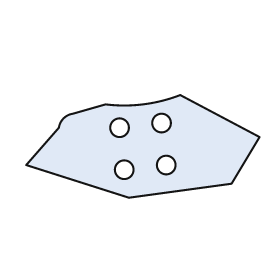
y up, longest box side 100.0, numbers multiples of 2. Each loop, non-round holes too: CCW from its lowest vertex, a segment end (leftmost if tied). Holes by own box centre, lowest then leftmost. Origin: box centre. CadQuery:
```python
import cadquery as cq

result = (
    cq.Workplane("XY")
    .moveTo(-6.0, -22.0)
    .lineTo(38.0, -16.0)
    .lineTo(50.0, 4.0)
    .lineTo(16.0, 22.0)
    .threePointArc((0.0, 18.0), (-16.0, 18.0))
    .lineTo(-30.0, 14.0)
    .threePointArc((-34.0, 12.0), (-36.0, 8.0))
    .lineTo(-50.0, -8.0)
    .close()
    .moveTo(-8.0, -10.0)
    .circle(4.0)
    .moveTo(10.0, -8.0)
    .circle(4.0)
    .moveTo(-10.0, 8.0)
    .circle(4.0)
    .moveTo(8.0, 10.0)
    .circle(4.0)
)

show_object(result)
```